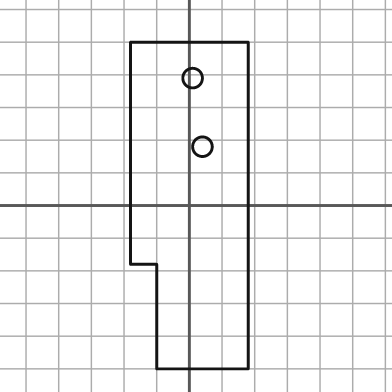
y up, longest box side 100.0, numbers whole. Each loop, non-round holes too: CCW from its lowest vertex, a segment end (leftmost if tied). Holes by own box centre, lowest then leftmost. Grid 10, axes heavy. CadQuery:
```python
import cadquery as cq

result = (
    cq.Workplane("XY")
    .moveTo(-10.0, -50.0)
    .lineTo(18.0, -50.0)
    .lineTo(18.0, 50.0)
    .lineTo(-18.0, 50.0)
    .lineTo(-18.0, -18.0)
    .lineTo(-10.0, -18.0)
    .close()
    .moveTo(4.0, 18.0)
    .circle(3.0)
    .moveTo(1.0, 39.0)
    .circle(3.0)
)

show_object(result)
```